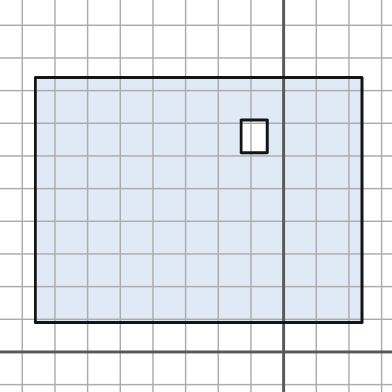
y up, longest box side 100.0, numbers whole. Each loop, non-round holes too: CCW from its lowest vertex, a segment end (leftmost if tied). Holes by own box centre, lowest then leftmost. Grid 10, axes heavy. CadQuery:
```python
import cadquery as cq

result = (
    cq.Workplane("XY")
    .moveTo(-76.0, 9.0)
    .lineTo(24.0, 9.0)
    .lineTo(24.0, 84.0)
    .lineTo(-76.0, 84.0)
    .close()
    .moveTo(-13.0, 61.0)
    .lineTo(-5.0, 61.0)
    .lineTo(-5.0, 71.0)
    .lineTo(-13.0, 71.0)
    .close()
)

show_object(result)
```